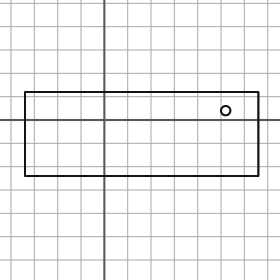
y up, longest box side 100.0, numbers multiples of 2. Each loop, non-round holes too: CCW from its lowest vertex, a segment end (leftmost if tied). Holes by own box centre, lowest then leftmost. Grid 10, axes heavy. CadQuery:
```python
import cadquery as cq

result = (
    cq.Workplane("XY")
    .moveTo(-34.0, -24.0)
    .lineTo(66.0, -24.0)
    .lineTo(66.0, 12.0)
    .lineTo(-34.0, 12.0)
    .close()
    .moveTo(52.0, 4.0)
    .circle(2.0)
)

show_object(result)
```